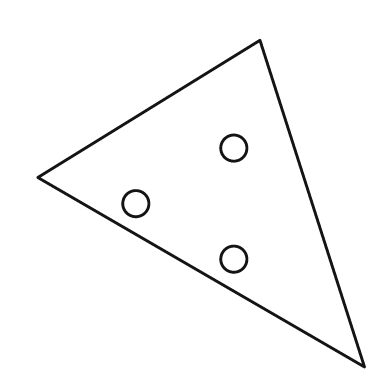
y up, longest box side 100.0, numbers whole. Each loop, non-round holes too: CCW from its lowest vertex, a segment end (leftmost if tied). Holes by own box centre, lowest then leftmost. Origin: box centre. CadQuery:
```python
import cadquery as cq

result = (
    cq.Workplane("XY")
    .moveTo(50.0, -50.0)
    .lineTo(18.0, 50.0)
    .lineTo(-50.0, 8.0)
    .close()
    .moveTo(10.0, -17.0)
    .circle(4.0)
    .moveTo(-20.0, 0.0)
    .circle(4.0)
    .moveTo(10.0, 17.0)
    .circle(4.0)
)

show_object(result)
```